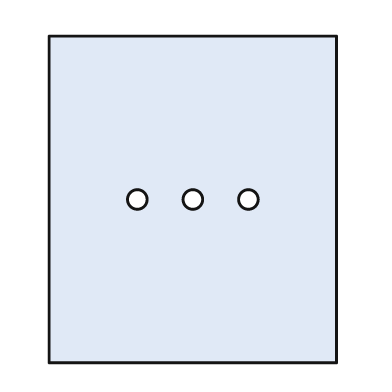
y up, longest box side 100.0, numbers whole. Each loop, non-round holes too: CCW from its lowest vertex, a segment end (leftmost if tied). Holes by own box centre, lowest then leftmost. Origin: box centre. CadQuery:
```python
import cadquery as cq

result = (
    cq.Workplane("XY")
    .moveTo(-44.0, -50.0)
    .lineTo(44.0, -50.0)
    .lineTo(44.0, 50.0)
    .lineTo(-44.0, 50.0)
    .close()
    .moveTo(-17.0, 0.0)
    .circle(3.0)
    .moveTo(0.0, 0.0)
    .circle(3.0)
    .moveTo(17.0, 0.0)
    .circle(3.0)
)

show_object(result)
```